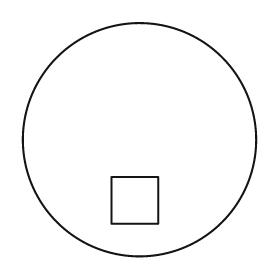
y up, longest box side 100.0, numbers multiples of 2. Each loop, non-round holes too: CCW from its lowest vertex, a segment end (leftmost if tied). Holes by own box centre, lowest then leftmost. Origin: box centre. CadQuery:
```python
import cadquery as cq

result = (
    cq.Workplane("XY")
    .moveTo(0.0, 0.0)
    .circle(50.0)
    .moveTo(-12.0, -36.0)
    .lineTo(8.0, -36.0)
    .lineTo(8.0, -16.0)
    .lineTo(-12.0, -16.0)
    .close()
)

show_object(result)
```